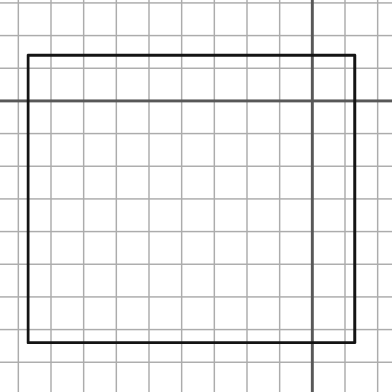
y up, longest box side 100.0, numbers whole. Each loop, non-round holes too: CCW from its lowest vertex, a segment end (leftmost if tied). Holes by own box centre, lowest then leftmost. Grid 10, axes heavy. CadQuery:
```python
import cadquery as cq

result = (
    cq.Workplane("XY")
    .moveTo(-87.0, -74.0)
    .lineTo(13.0, -74.0)
    .lineTo(13.0, 14.0)
    .lineTo(-87.0, 14.0)
    .close()
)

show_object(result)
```